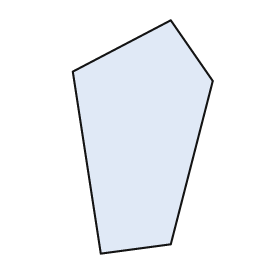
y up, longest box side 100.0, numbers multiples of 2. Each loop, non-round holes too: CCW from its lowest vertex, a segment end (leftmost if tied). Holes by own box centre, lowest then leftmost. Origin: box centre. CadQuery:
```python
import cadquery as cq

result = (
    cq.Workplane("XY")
    .moveTo(-18.0, -50.0)
    .lineTo(12.0, -46.0)
    .lineTo(30.0, 24.0)
    .lineTo(12.0, 50.0)
    .lineTo(-30.0, 28.0)
    .close()
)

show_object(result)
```